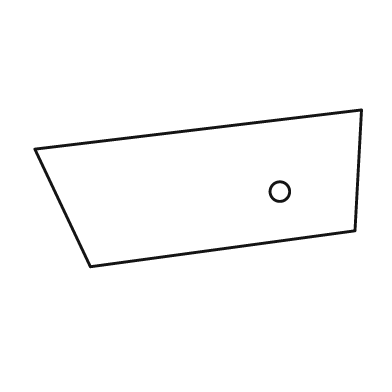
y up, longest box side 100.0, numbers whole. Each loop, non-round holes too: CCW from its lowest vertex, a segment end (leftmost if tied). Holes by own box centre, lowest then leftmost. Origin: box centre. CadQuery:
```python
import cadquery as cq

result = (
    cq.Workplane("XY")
    .moveTo(-33.0, -24.0)
    .lineTo(48.0, -13.0)
    .lineTo(50.0, 24.0)
    .lineTo(-50.0, 12.0)
    .close()
    .moveTo(25.0, -1.0)
    .circle(3.0)
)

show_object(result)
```